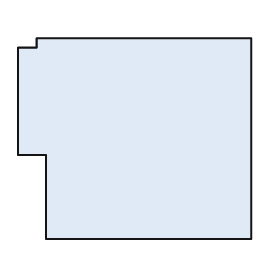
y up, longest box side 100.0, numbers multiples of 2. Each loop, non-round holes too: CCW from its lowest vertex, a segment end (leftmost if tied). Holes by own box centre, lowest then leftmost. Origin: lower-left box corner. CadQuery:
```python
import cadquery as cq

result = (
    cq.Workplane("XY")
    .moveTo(12.0, 0.0)
    .lineTo(100.0, 0.0)
    .lineTo(100.0, 86.0)
    .lineTo(8.0, 86.0)
    .lineTo(8.0, 82.0)
    .lineTo(0.0, 82.0)
    .lineTo(0.0, 36.0)
    .lineTo(12.0, 36.0)
    .close()
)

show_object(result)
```